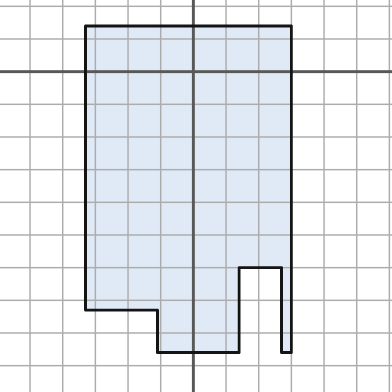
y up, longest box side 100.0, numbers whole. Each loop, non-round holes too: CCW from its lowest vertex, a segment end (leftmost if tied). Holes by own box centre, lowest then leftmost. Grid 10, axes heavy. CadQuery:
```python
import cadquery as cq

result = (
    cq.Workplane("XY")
    .moveTo(-11.0, -86.0)
    .lineTo(14.0, -86.0)
    .lineTo(14.0, -60.0)
    .lineTo(27.0, -60.0)
    .lineTo(27.0, -86.0)
    .lineTo(30.0, -86.0)
    .lineTo(30.0, 14.0)
    .lineTo(-33.0, 14.0)
    .lineTo(-33.0, -73.0)
    .lineTo(-11.0, -73.0)
    .close()
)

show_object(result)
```